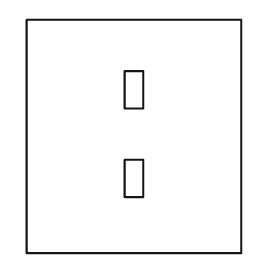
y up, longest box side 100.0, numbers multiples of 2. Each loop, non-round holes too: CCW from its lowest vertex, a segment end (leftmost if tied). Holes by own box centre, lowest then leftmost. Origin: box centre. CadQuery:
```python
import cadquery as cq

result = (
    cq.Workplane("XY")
    .moveTo(-46.0, -50.0)
    .lineTo(46.0, -50.0)
    .lineTo(46.0, 50.0)
    .lineTo(-46.0, 50.0)
    .close()
    .moveTo(-4.0, -26.0)
    .lineTo(4.0, -26.0)
    .lineTo(4.0, -10.0)
    .lineTo(-4.0, -10.0)
    .close()
    .moveTo(-4.0, 12.0)
    .lineTo(4.0, 12.0)
    .lineTo(4.0, 28.0)
    .lineTo(-4.0, 28.0)
    .close()
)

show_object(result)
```